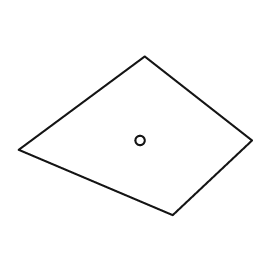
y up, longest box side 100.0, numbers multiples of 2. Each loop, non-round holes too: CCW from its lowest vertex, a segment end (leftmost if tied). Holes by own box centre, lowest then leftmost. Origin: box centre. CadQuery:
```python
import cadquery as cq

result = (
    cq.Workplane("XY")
    .moveTo(16.0, -34.0)
    .lineTo(50.0, -2.0)
    .lineTo(4.0, 34.0)
    .lineTo(-50.0, -6.0)
    .close()
    .moveTo(2.0, -2.0)
    .circle(2.0)
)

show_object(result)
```